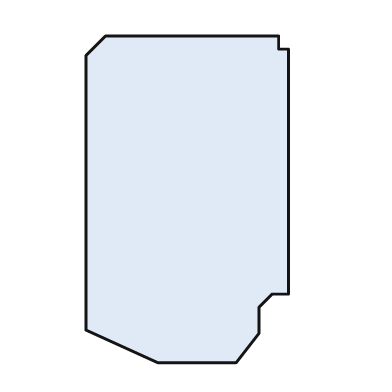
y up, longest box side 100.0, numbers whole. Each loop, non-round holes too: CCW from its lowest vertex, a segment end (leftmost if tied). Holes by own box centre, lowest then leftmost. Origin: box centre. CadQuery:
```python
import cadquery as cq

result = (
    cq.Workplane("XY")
    .moveTo(-9.0, -50.0)
    .lineTo(15.0, -50.0)
    .lineTo(22.0, -41.0)
    .lineTo(22.0, -33.0)
    .lineTo(26.0, -29.0)
    .lineTo(31.0, -29.0)
    .lineTo(31.0, 46.0)
    .lineTo(28.0, 46.0)
    .lineTo(28.0, 50.0)
    .lineTo(-25.0, 50.0)
    .lineTo(-31.0, 44.0)
    .lineTo(-31.0, -40.0)
    .close()
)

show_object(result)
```